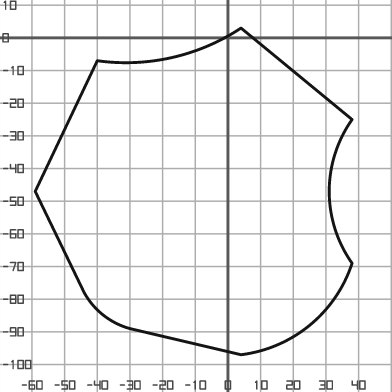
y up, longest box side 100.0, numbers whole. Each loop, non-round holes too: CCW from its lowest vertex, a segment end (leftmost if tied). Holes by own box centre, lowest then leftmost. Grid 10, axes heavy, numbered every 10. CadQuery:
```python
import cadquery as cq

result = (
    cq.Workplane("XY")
    .moveTo(4.0, -97.0)
    .threePointArc((25.0, -88.0), (38.0, -69.0))
    .threePointArc((31.0, -47.0), (38.0, -25.0))
    .lineTo(4.0, 3.0)
    .threePointArc((-17.0, -6.0), (-40.0, -7.0))
    .lineTo(-59.0, -47.0)
    .lineTo(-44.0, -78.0)
    .threePointArc((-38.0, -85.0), (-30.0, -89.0))
    .close()
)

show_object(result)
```